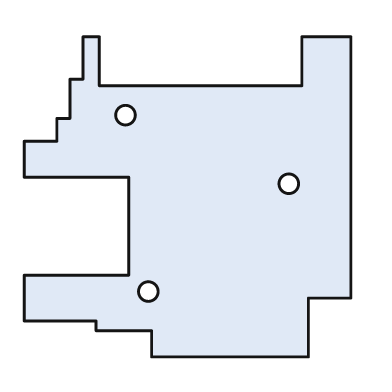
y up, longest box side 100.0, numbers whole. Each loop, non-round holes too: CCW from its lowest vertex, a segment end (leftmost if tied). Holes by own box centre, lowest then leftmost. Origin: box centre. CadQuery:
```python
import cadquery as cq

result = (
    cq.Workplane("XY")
    .moveTo(-11.0, -49.0)
    .lineTo(37.0, -49.0)
    .lineTo(37.0, -31.0)
    .lineTo(50.0, -31.0)
    .lineTo(50.0, 49.0)
    .lineTo(35.0, 49.0)
    .lineTo(35.0, 34.0)
    .lineTo(-27.0, 34.0)
    .lineTo(-27.0, 49.0)
    .lineTo(-32.0, 49.0)
    .lineTo(-32.0, 36.0)
    .lineTo(-36.0, 36.0)
    .lineTo(-36.0, 24.0)
    .lineTo(-40.0, 24.0)
    .lineTo(-40.0, 17.0)
    .lineTo(-50.0, 17.0)
    .lineTo(-50.0, 6.0)
    .lineTo(-18.0, 6.0)
    .lineTo(-18.0, -24.0)
    .lineTo(-50.0, -24.0)
    .lineTo(-50.0, -38.0)
    .lineTo(-28.0, -38.0)
    .lineTo(-28.0, -41.0)
    .lineTo(-11.0, -41.0)
    .close()
    .moveTo(-12.0, -29.0)
    .circle(3.0)
    .moveTo(31.0, 4.0)
    .circle(3.0)
    .moveTo(-19.0, 25.0)
    .circle(3.0)
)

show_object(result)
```